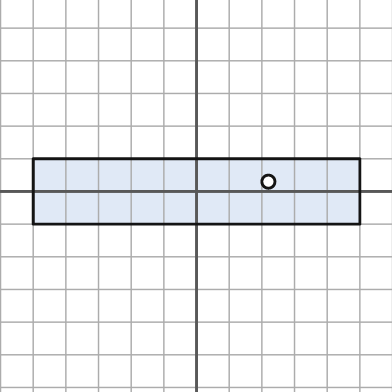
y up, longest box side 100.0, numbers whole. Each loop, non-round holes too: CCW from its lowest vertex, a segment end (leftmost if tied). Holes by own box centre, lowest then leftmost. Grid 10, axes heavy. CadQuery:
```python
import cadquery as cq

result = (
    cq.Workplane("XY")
    .moveTo(-50.0, -10.0)
    .lineTo(50.0, -10.0)
    .lineTo(50.0, 10.0)
    .lineTo(-50.0, 10.0)
    .close()
    .moveTo(22.0, 3.0)
    .circle(2.0)
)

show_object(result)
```